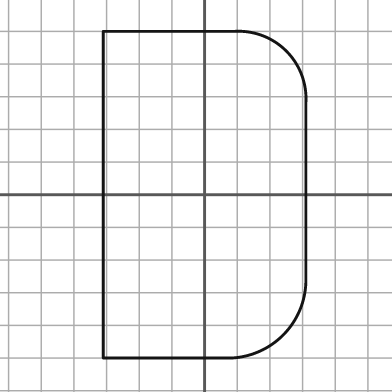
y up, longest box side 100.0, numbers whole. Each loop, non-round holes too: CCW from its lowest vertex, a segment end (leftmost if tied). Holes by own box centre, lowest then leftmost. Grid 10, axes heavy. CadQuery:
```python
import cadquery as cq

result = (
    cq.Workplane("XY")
    .moveTo(-31.0, -50.0)
    .lineTo(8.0, -50.0)
    .threePointArc((24.0, -43.0), (31.0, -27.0))
    .lineTo(31.0, 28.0)
    .threePointArc((25.0, 44.0), (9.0, 50.0))
    .lineTo(-31.0, 50.0)
    .close()
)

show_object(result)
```